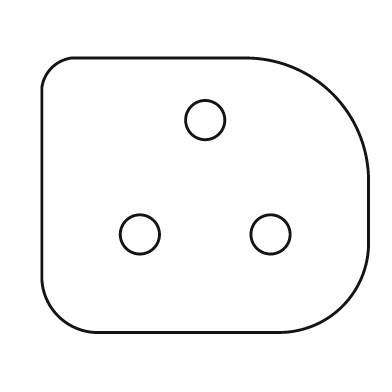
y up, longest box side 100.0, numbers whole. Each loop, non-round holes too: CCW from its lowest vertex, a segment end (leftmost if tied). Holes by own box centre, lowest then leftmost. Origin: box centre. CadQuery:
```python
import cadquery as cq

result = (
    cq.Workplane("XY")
    .moveTo(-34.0, -42.0)
    .lineTo(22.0, -42.0)
    .threePointArc((42.0, -34.0), (50.0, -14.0))
    .lineTo(50.0, 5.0)
    .threePointArc((39.0, 31.0), (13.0, 42.0))
    .lineTo(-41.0, 42.0)
    .threePointArc((-47.0, 39.0), (-50.0, 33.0))
    .lineTo(-50.0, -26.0)
    .threePointArc((-45.0, -37.0), (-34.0, -42.0))
    .close()
    .moveTo(-20.0, -12.0)
    .circle(6.0)
    .moveTo(20.0, -12.0)
    .circle(6.0)
    .moveTo(0.0, 23.0)
    .circle(6.0)
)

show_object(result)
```